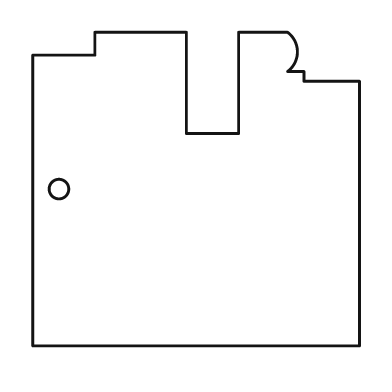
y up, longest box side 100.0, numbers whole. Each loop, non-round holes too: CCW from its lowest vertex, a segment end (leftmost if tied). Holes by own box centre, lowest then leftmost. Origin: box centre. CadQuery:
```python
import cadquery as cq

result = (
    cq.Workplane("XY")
    .moveTo(-50.0, -48.0)
    .lineTo(50.0, -48.0)
    .lineTo(50.0, 33.0)
    .lineTo(33.0, 33.0)
    .lineTo(33.0, 36.0)
    .lineTo(28.0, 36.0)
    .threePointArc((31.0, 42.0), (28.0, 48.0))
    .lineTo(13.0, 48.0)
    .lineTo(13.0, 17.0)
    .lineTo(-3.0, 17.0)
    .lineTo(-3.0, 48.0)
    .lineTo(-31.0, 48.0)
    .lineTo(-31.0, 41.0)
    .lineTo(-50.0, 41.0)
    .close()
    .moveTo(-42.0, 0.0)
    .circle(3.0)
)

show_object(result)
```